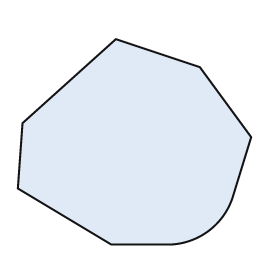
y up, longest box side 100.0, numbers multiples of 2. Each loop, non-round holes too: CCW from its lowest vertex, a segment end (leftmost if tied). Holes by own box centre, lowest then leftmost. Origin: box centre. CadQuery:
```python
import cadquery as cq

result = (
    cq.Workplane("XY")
    .moveTo(-10.0, -44.0)
    .lineTo(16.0, -44.0)
    .threePointArc((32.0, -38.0), (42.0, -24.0))
    .lineTo(50.0, 2.0)
    .lineTo(28.0, 32.0)
    .lineTo(-8.0, 44.0)
    .lineTo(-48.0, 8.0)
    .lineTo(-50.0, -20.0)
    .close()
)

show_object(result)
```